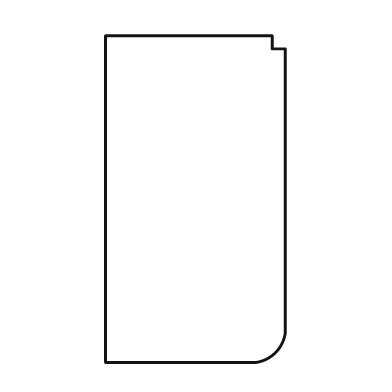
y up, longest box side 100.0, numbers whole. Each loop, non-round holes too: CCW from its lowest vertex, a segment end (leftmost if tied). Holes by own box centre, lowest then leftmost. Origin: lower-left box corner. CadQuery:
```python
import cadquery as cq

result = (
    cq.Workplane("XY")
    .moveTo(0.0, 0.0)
    .lineTo(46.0, 0.0)
    .threePointArc((52.0, 3.0), (55.0, 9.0))
    .lineTo(55.0, 96.0)
    .lineTo(51.0, 96.0)
    .lineTo(51.0, 100.0)
    .lineTo(0.0, 100.0)
    .close()
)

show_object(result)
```